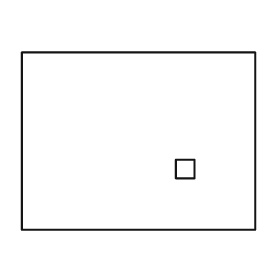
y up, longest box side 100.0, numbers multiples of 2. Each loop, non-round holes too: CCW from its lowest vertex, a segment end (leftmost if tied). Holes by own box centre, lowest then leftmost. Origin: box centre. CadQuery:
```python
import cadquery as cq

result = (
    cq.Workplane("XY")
    .moveTo(-50.0, -38.0)
    .lineTo(50.0, -38.0)
    .lineTo(50.0, 38.0)
    .lineTo(-50.0, 38.0)
    .close()
    .moveTo(16.0, -16.0)
    .lineTo(24.0, -16.0)
    .lineTo(24.0, -8.0)
    .lineTo(16.0, -8.0)
    .close()
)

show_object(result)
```